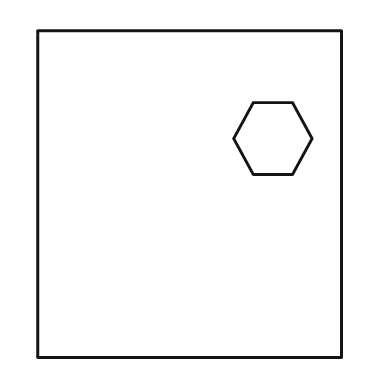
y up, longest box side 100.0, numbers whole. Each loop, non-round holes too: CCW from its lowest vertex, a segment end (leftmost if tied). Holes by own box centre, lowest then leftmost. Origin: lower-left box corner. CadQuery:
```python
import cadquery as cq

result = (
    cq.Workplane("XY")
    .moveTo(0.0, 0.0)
    .lineTo(93.0, 0.0)
    .lineTo(93.0, 100.0)
    .lineTo(0.0, 100.0)
    .close()
    .moveTo(66.0, 56.0)
    .lineTo(78.0, 56.0)
    .lineTo(84.0, 67.0)
    .lineTo(78.0, 78.0)
    .lineTo(66.0, 78.0)
    .lineTo(60.0, 67.0)
    .close()
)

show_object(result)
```